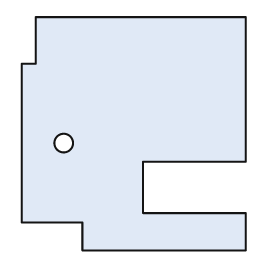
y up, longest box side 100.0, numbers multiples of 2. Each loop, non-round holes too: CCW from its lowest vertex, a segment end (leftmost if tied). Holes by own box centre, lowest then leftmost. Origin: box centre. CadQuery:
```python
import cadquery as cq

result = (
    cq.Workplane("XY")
    .moveTo(-22.0, -50.0)
    .lineTo(48.0, -50.0)
    .lineTo(48.0, -34.0)
    .lineTo(4.0, -34.0)
    .lineTo(4.0, -12.0)
    .lineTo(48.0, -12.0)
    .lineTo(48.0, 50.0)
    .lineTo(-42.0, 50.0)
    .lineTo(-42.0, 30.0)
    .lineTo(-48.0, 30.0)
    .lineTo(-48.0, -38.0)
    .lineTo(-22.0, -38.0)
    .close()
    .moveTo(-30.0, -4.0)
    .circle(4.0)
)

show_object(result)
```